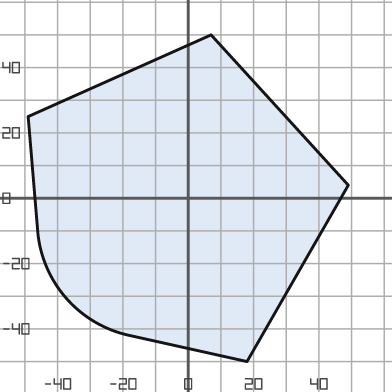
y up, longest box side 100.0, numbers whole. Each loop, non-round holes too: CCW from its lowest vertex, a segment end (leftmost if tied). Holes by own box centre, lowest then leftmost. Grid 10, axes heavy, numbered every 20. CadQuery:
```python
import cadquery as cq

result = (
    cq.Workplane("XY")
    .moveTo(18.0, -50.0)
    .lineTo(49.0, 4.0)
    .lineTo(7.0, 50.0)
    .lineTo(-49.0, 25.0)
    .lineTo(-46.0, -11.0)
    .threePointArc((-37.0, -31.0), (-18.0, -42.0))
    .close()
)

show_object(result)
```